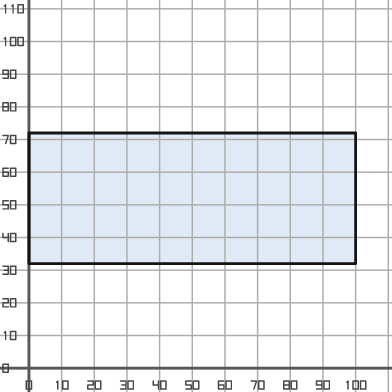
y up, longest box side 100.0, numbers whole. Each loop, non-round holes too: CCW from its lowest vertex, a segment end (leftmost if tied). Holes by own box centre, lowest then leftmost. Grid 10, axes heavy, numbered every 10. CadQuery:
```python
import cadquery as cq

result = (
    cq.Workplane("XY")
    .moveTo(0.0, 32.0)
    .lineTo(100.0, 32.0)
    .lineTo(100.0, 72.0)
    .lineTo(0.0, 72.0)
    .close()
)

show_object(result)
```